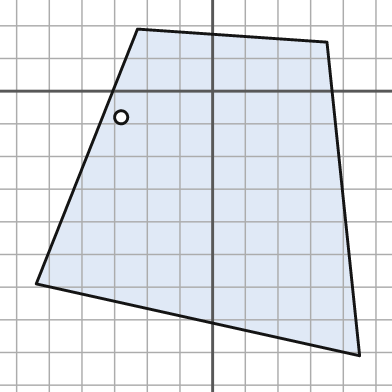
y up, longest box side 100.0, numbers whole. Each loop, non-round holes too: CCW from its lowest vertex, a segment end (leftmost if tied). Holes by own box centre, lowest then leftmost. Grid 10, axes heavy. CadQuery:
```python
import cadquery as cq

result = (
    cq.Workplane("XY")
    .moveTo(45.0, -81.0)
    .lineTo(35.0, 15.0)
    .lineTo(-23.0, 19.0)
    .lineTo(-54.0, -59.0)
    .close()
    .moveTo(-28.0, -8.0)
    .circle(2.0)
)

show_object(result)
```